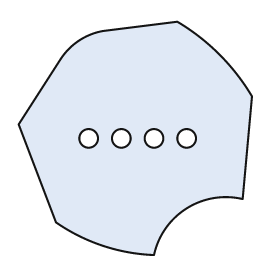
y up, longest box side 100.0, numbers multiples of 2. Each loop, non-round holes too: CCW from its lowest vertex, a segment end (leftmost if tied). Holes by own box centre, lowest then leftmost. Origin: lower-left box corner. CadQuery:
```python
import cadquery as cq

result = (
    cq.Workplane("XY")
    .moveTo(58.0, 0.0)
    .threePointArc((72.0, 20.0), (96.0, 24.0))
    .lineTo(100.0, 68.0)
    .threePointArc((86.0, 86.0), (68.0, 100.0))
    .lineTo(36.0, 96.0)
    .threePointArc((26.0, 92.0), (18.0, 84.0))
    .lineTo(0.0, 56.0)
    .lineTo(16.0, 14.0)
    .threePointArc((36.0, 4.0), (58.0, 0.0))
    .close()
    .moveTo(30.0, 50.0)
    .circle(4.0)
    .moveTo(44.0, 50.0)
    .circle(4.0)
    .moveTo(58.0, 50.0)
    .circle(4.0)
    .moveTo(72.0, 50.0)
    .circle(4.0)
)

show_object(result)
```